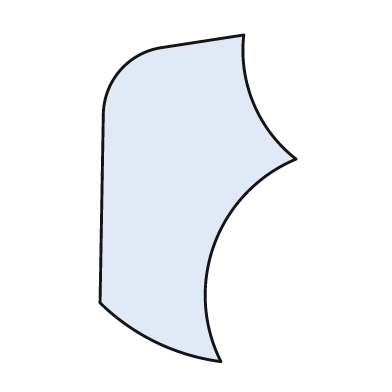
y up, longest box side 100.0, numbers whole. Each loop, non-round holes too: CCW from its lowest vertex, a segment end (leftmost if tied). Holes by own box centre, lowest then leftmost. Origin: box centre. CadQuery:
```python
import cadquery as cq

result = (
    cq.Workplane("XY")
    .moveTo(7.0, -50.0)
    .threePointArc((5.0, -14.0), (30.0, 12.0))
    .threePointArc((17.0, 29.0), (14.0, 50.0))
    .lineTo(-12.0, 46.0)
    .threePointArc((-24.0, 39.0), (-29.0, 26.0))
    .lineTo(-30.0, -32.0)
    .threePointArc((-13.0, -44.0), (7.0, -50.0))
    .close()
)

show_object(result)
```